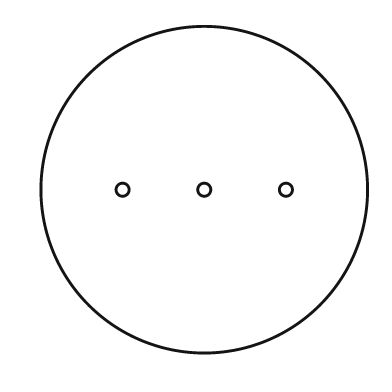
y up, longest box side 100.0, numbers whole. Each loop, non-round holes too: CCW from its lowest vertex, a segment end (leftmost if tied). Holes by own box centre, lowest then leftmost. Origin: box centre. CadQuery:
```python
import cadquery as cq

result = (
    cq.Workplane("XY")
    .moveTo(0.0, 0.0)
    .circle(50.0)
    .moveTo(-25.0, 0.0)
    .circle(2.0)
    .moveTo(0.0, 0.0)
    .circle(2.0)
    .moveTo(25.0, 0.0)
    .circle(2.0)
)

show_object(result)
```